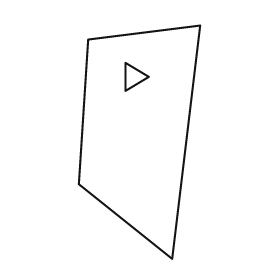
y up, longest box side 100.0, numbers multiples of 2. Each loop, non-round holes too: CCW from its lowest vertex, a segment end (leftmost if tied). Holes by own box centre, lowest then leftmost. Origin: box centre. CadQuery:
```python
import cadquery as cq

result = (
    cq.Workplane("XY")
    .moveTo(14.0, -50.0)
    .lineTo(26.0, 50.0)
    .lineTo(-22.0, 44.0)
    .lineTo(-26.0, -18.0)
    .close()
    .moveTo(-6.0, 22.0)
    .lineTo(4.0, 28.0)
    .lineTo(-6.0, 34.0)
    .close()
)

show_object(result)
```